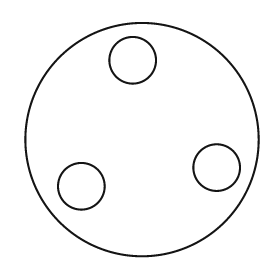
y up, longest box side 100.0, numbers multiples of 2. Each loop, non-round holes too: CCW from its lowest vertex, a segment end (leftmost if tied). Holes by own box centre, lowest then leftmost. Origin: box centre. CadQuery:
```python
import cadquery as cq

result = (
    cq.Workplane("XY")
    .moveTo(0.0, 0.0)
    .circle(50.0)
    .moveTo(-26.0, -20.0)
    .circle(10.0)
    .moveTo(32.0, -12.0)
    .circle(10.0)
    .moveTo(-4.0, 34.0)
    .circle(10.0)
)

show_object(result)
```